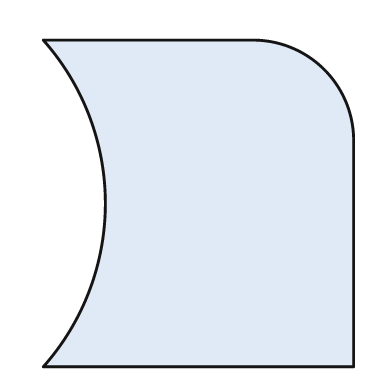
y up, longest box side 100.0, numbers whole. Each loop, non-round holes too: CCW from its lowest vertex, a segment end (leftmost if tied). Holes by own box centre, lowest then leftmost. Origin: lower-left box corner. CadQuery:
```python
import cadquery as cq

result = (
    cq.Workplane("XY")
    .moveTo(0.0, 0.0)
    .lineTo(95.0, 0.0)
    .lineTo(95.0, 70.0)
    .threePointArc((86.0, 91.0), (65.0, 100.0))
    .lineTo(0.0, 100.0)
    .threePointArc((19.0, 50.0), (0.0, 0.0))
    .close()
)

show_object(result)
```